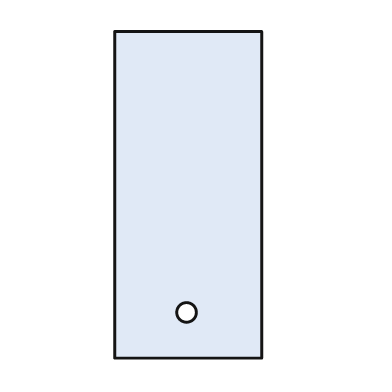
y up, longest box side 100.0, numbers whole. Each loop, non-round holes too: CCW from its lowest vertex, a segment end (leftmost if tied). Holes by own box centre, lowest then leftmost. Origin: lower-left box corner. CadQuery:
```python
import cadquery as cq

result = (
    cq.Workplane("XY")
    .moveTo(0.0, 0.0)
    .lineTo(45.0, 0.0)
    .lineTo(45.0, 100.0)
    .lineTo(0.0, 100.0)
    .close()
    .moveTo(22.0, 14.0)
    .circle(3.0)
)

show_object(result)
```